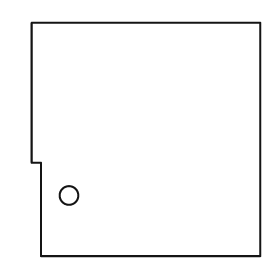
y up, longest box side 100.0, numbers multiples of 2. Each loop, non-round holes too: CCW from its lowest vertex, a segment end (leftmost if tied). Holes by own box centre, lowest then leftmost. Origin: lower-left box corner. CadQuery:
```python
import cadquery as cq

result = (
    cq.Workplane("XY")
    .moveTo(4.0, 0.0)
    .lineTo(98.0, 0.0)
    .lineTo(98.0, 100.0)
    .lineTo(0.0, 100.0)
    .lineTo(0.0, 40.0)
    .lineTo(4.0, 40.0)
    .close()
    .moveTo(16.0, 26.0)
    .circle(4.0)
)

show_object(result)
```